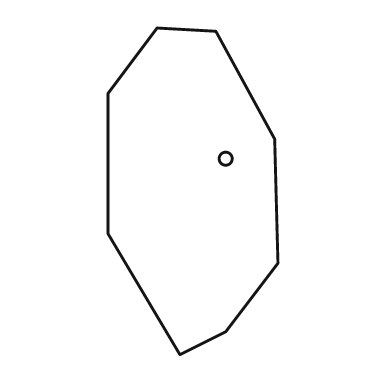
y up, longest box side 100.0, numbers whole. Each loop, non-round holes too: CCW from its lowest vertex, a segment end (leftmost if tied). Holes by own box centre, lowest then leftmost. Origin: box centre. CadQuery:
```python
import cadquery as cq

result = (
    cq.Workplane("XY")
    .moveTo(-4.0, -50.0)
    .lineTo(10.0, -43.0)
    .lineTo(26.0, -22.0)
    .lineTo(25.0, 16.0)
    .lineTo(7.0, 49.0)
    .lineTo(-11.0, 50.0)
    .lineTo(-26.0, 30.0)
    .lineTo(-26.0, -13.0)
    .close()
    .moveTo(10.0, 10.0)
    .circle(2.0)
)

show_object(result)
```